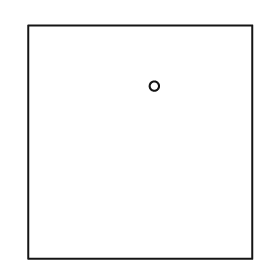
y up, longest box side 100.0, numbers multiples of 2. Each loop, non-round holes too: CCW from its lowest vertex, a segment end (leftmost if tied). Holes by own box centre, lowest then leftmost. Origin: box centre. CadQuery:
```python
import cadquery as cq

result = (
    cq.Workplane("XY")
    .moveTo(-48.0, -50.0)
    .lineTo(48.0, -50.0)
    .lineTo(48.0, 50.0)
    .lineTo(-48.0, 50.0)
    .close()
    .moveTo(6.0, 24.0)
    .circle(2.0)
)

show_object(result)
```